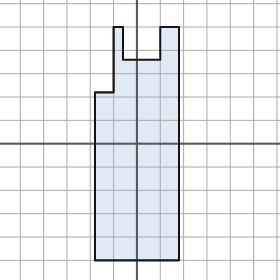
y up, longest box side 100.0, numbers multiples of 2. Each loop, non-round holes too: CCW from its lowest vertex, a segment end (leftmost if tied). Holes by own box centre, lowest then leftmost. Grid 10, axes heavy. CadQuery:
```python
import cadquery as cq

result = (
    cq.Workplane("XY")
    .moveTo(-18.0, -50.0)
    .lineTo(18.0, -50.0)
    .lineTo(18.0, 50.0)
    .lineTo(10.0, 50.0)
    .lineTo(10.0, 36.0)
    .lineTo(-6.0, 36.0)
    .lineTo(-6.0, 50.0)
    .lineTo(-10.0, 50.0)
    .lineTo(-10.0, 22.0)
    .lineTo(-18.0, 22.0)
    .close()
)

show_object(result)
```